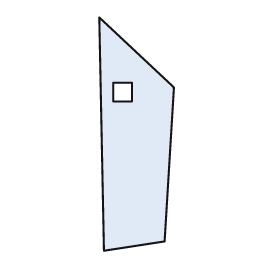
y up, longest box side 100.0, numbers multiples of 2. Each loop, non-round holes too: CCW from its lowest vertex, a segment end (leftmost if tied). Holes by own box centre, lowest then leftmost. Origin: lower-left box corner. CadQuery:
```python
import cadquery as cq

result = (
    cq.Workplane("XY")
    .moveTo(2.0, 0.0)
    .lineTo(28.0, 4.0)
    .lineTo(32.0, 70.0)
    .lineTo(0.0, 100.0)
    .close()
    .moveTo(6.0, 64.0)
    .lineTo(14.0, 64.0)
    .lineTo(14.0, 72.0)
    .lineTo(6.0, 72.0)
    .close()
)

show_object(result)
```